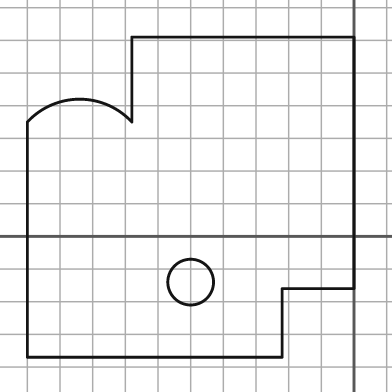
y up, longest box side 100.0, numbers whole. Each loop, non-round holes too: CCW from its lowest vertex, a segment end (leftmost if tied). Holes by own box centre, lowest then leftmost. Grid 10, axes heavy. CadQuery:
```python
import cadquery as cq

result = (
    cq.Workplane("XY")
    .moveTo(-100.0, -37.0)
    .lineTo(-22.0, -37.0)
    .lineTo(-22.0, -16.0)
    .lineTo(0.0, -16.0)
    .lineTo(0.0, 61.0)
    .lineTo(-68.0, 61.0)
    .lineTo(-68.0, 35.0)
    .threePointArc((-84.0, 42.0), (-100.0, 35.0))
    .close()
    .moveTo(-50.0, -14.0)
    .circle(7.0)
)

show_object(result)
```